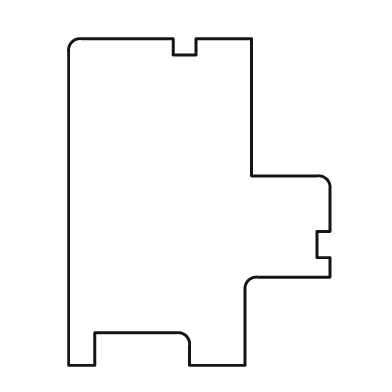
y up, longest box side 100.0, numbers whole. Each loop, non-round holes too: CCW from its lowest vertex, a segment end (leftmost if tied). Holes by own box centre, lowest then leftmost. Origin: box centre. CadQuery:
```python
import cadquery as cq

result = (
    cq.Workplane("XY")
    .moveTo(-40.0, -50.0)
    .lineTo(-32.0, -50.0)
    .lineTo(-32.0, -40.0)
    .lineTo(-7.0, -40.0)
    .threePointArc((-4.0, -41.0), (-3.0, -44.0))
    .lineTo(-3.0, -50.0)
    .lineTo(14.0, -50.0)
    .lineTo(14.0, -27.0)
    .threePointArc((15.0, -24.0), (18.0, -23.0))
    .lineTo(40.0, -23.0)
    .lineTo(40.0, -17.0)
    .lineTo(36.0, -17.0)
    .lineTo(36.0, -9.0)
    .lineTo(40.0, -9.0)
    .lineTo(40.0, 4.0)
    .threePointArc((39.0, 7.0), (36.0, 8.0))
    .lineTo(16.0, 8.0)
    .lineTo(16.0, 50.0)
    .lineTo(-1.0, 50.0)
    .lineTo(-1.0, 45.0)
    .lineTo(-8.0, 45.0)
    .lineTo(-8.0, 50.0)
    .lineTo(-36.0, 50.0)
    .threePointArc((-39.0, 49.0), (-40.0, 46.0))
    .close()
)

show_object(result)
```